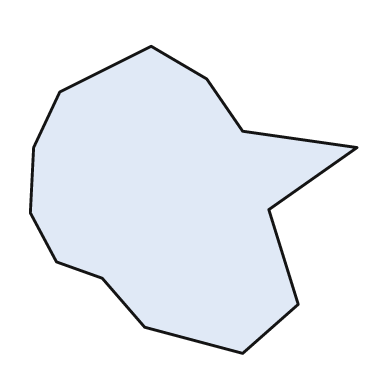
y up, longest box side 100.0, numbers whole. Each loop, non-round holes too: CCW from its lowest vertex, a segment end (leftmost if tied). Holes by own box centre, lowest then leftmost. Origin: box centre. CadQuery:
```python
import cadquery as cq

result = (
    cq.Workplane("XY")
    .moveTo(15.0, -47.0)
    .lineTo(32.0, -32.0)
    .lineTo(23.0, -3.0)
    .lineTo(50.0, 16.0)
    .lineTo(15.0, 21.0)
    .lineTo(4.0, 37.0)
    .lineTo(-13.0, 47.0)
    .lineTo(-41.0, 33.0)
    .lineTo(-49.0, 16.0)
    .lineTo(-50.0, -4.0)
    .lineTo(-42.0, -19.0)
    .lineTo(-28.0, -24.0)
    .lineTo(-15.0, -39.0)
    .close()
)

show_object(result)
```